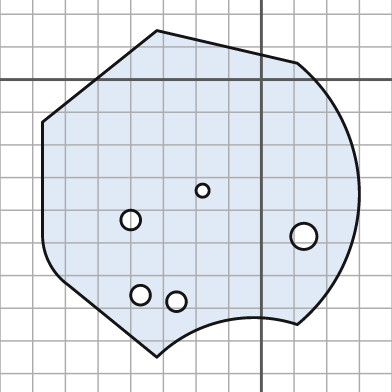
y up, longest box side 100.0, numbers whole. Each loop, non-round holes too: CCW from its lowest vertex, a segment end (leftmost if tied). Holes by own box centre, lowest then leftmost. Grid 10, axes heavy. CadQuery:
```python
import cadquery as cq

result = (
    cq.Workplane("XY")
    .moveTo(-32.0, -85.0)
    .threePointArc((-12.0, -74.0), (11.0, -75.0))
    .threePointArc((25.0, -57.0), (30.0, -35.0))
    .threePointArc((25.0, -13.0), (11.0, 5.0))
    .lineTo(-32.0, 15.0)
    .lineTo(-67.0, -13.0)
    .lineTo(-67.0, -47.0)
    .threePointArc((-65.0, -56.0), (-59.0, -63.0))
    .close()
    .moveTo(-26.0, -68.0)
    .circle(3.0)
    .moveTo(-37.0, -66.0)
    .circle(3.0)
    .moveTo(13.0, -48.0)
    .circle(4.0)
    .moveTo(-40.0, -43.0)
    .circle(3.0)
    .moveTo(-18.0, -34.0)
    .circle(2.0)
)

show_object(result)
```